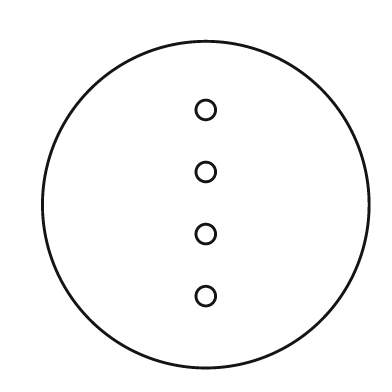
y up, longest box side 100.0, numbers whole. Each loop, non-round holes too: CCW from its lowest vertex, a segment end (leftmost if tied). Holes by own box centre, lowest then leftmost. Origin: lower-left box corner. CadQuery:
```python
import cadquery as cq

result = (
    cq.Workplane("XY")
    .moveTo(50.0, 50.0)
    .circle(50.0)
    .moveTo(50.0, 22.0)
    .circle(3.0)
    .moveTo(50.0, 41.0)
    .circle(3.0)
    .moveTo(50.0, 60.0)
    .circle(3.0)
    .moveTo(50.0, 79.0)
    .circle(3.0)
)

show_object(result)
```